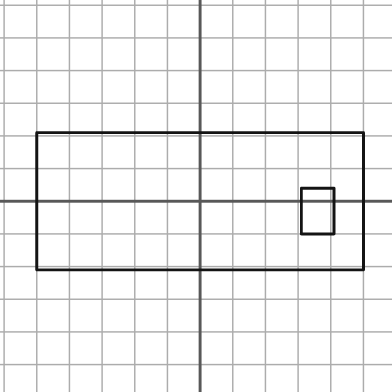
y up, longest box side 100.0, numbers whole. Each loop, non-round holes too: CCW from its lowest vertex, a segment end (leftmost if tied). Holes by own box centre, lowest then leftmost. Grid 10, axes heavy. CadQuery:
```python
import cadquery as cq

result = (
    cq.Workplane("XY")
    .moveTo(-50.0, -21.0)
    .lineTo(50.0, -21.0)
    .lineTo(50.0, 21.0)
    .lineTo(-50.0, 21.0)
    .close()
    .moveTo(31.0, -10.0)
    .lineTo(41.0, -10.0)
    .lineTo(41.0, 4.0)
    .lineTo(31.0, 4.0)
    .close()
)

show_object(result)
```